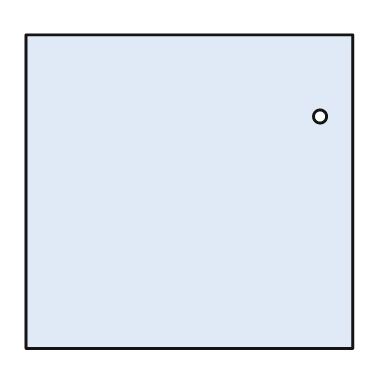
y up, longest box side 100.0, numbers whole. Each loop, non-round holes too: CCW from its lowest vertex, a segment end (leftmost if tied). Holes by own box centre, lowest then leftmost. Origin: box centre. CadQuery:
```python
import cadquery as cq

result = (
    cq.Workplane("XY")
    .moveTo(-50.0, -48.0)
    .lineTo(50.0, -48.0)
    .lineTo(50.0, 48.0)
    .lineTo(-50.0, 48.0)
    .close()
    .moveTo(40.0, 23.0)
    .circle(2.0)
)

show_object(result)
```